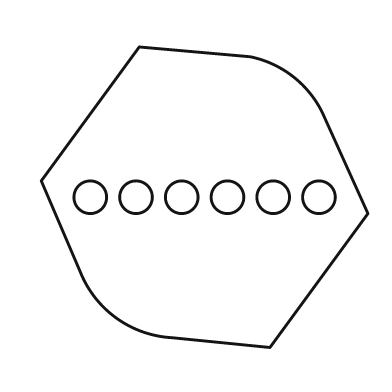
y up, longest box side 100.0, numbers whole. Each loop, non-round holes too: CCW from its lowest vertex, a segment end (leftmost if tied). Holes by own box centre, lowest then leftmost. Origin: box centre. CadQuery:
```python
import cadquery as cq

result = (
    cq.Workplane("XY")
    .moveTo(20.0, -46.0)
    .lineTo(50.0, -5.0)
    .lineTo(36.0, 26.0)
    .threePointArc((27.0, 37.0), (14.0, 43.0))
    .lineTo(-20.0, 46.0)
    .lineTo(-50.0, 5.0)
    .lineTo(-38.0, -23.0)
    .threePointArc((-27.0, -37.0), (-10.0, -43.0))
    .close()
    .moveTo(-35.0, 0.0)
    .circle(5.0)
    .moveTo(-21.0, 0.0)
    .circle(5.0)
    .moveTo(-7.0, 0.0)
    .circle(5.0)
    .moveTo(7.0, 0.0)
    .circle(5.0)
    .moveTo(21.0, 0.0)
    .circle(5.0)
    .moveTo(35.0, 0.0)
    .circle(5.0)
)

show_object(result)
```